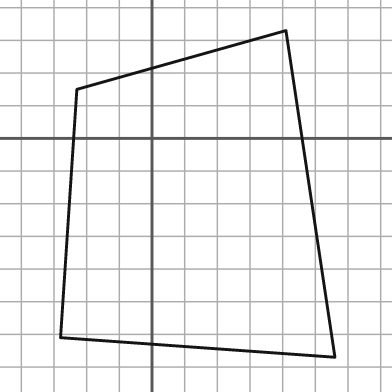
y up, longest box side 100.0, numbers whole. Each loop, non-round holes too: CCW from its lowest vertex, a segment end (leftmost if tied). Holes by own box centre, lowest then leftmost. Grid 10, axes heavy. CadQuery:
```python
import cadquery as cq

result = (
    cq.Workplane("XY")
    .moveTo(56.0, -67.0)
    .lineTo(41.0, 33.0)
    .lineTo(-23.0, 15.0)
    .lineTo(-28.0, -61.0)
    .close()
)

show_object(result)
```